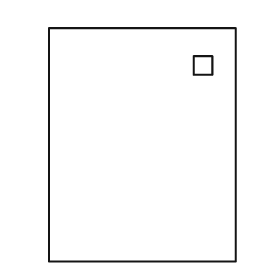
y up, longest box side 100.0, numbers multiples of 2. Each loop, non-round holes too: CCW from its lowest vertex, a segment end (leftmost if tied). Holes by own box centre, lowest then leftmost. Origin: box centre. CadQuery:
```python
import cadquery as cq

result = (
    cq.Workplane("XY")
    .moveTo(-40.0, -50.0)
    .lineTo(40.0, -50.0)
    .lineTo(40.0, 50.0)
    .lineTo(-40.0, 50.0)
    .close()
    .moveTo(22.0, 30.0)
    .lineTo(30.0, 30.0)
    .lineTo(30.0, 38.0)
    .lineTo(22.0, 38.0)
    .close()
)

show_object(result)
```